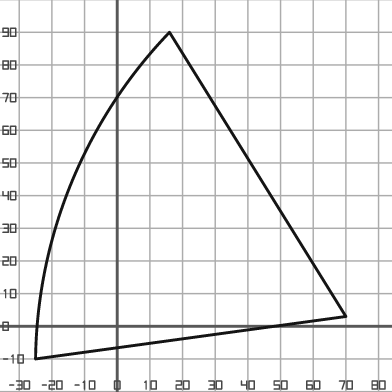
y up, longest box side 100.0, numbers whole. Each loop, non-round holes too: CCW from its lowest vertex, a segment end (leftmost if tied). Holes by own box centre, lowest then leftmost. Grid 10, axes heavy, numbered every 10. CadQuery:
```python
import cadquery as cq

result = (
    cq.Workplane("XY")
    .moveTo(-25.0, -10.0)
    .lineTo(70.0, 3.0)
    .lineTo(16.0, 90.0)
    .threePointArc((-14.0, 44.0), (-25.0, -10.0))
    .close()
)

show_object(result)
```